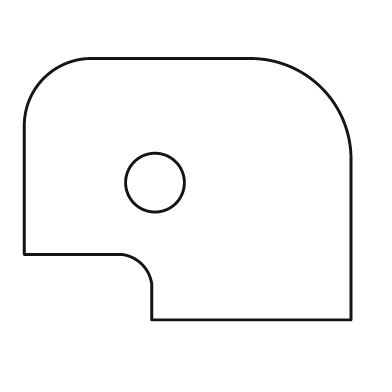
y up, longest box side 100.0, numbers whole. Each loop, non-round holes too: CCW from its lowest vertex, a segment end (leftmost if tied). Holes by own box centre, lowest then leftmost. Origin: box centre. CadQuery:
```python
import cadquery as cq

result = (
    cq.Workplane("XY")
    .moveTo(-11.0, -40.0)
    .lineTo(50.0, -40.0)
    .lineTo(50.0, 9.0)
    .threePointArc((41.0, 31.0), (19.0, 40.0))
    .lineTo(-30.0, 40.0)
    .threePointArc((-44.0, 34.0), (-50.0, 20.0))
    .lineTo(-50.0, -20.0)
    .lineTo(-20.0, -20.0)
    .threePointArc((-14.0, -23.0), (-11.0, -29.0))
    .close()
    .moveTo(-10.0, 2.0)
    .circle(9.0)
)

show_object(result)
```